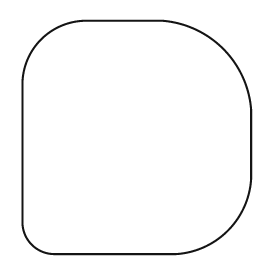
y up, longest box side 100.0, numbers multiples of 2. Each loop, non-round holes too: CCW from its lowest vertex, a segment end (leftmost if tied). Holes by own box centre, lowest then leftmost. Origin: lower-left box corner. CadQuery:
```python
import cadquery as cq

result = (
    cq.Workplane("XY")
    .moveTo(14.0, 0.0)
    .lineTo(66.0, 0.0)
    .threePointArc((88.0, 10.0), (98.0, 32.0))
    .lineTo(98.0, 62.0)
    .threePointArc((86.0, 88.0), (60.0, 100.0))
    .lineTo(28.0, 100.0)
    .threePointArc((8.0, 92.0), (0.0, 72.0))
    .lineTo(0.0, 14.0)
    .threePointArc((4.0, 4.0), (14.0, 0.0))
    .close()
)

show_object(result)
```